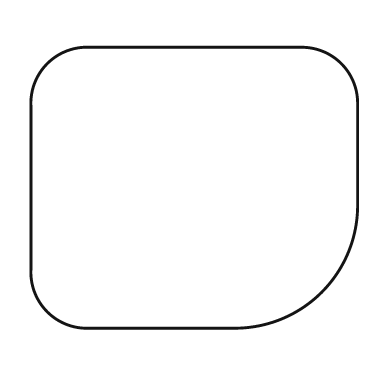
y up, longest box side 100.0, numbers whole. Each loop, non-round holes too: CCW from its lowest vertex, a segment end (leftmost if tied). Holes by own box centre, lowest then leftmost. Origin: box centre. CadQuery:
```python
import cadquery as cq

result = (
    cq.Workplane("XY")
    .moveTo(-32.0, -43.0)
    .lineTo(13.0, -43.0)
    .threePointArc((39.0, -32.0), (50.0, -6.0))
    .lineTo(50.0, 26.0)
    .threePointArc((45.0, 38.0), (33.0, 43.0))
    .lineTo(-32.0, 43.0)
    .threePointArc((-45.0, 38.0), (-50.0, 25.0))
    .lineTo(-50.0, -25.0)
    .threePointArc((-45.0, -38.0), (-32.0, -43.0))
    .close()
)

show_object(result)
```